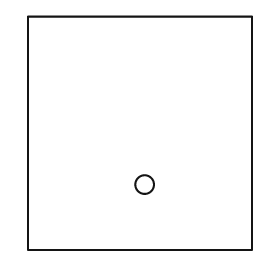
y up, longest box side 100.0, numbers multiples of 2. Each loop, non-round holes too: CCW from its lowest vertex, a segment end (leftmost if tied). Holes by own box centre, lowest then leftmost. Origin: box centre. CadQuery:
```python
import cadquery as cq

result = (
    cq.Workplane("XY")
    .moveTo(-48.0, -50.0)
    .lineTo(48.0, -50.0)
    .lineTo(48.0, 50.0)
    .lineTo(-48.0, 50.0)
    .close()
    .moveTo(2.0, -22.0)
    .circle(4.0)
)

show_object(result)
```